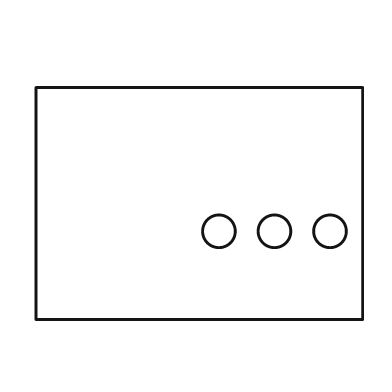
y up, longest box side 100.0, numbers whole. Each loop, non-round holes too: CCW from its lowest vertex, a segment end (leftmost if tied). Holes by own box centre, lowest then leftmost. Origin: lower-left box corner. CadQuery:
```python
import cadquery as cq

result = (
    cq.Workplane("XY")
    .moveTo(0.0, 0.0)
    .lineTo(100.0, 0.0)
    .lineTo(100.0, 71.0)
    .lineTo(0.0, 71.0)
    .close()
    .moveTo(56.0, 27.0)
    .circle(5.0)
    .moveTo(73.0, 27.0)
    .circle(5.0)
    .moveTo(90.0, 27.0)
    .circle(5.0)
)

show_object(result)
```